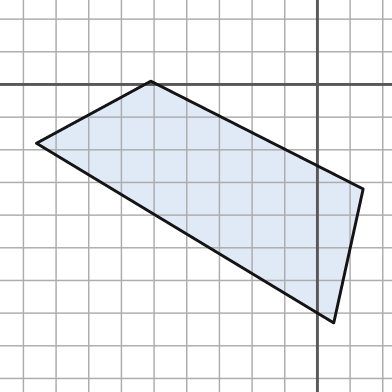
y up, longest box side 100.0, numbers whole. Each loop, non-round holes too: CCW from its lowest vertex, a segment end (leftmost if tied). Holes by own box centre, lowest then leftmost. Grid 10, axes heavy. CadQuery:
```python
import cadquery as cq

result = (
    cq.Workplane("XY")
    .moveTo(5.0, -73.0)
    .lineTo(14.0, -32.0)
    .lineTo(-51.0, 1.0)
    .lineTo(-86.0, -18.0)
    .close()
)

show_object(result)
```